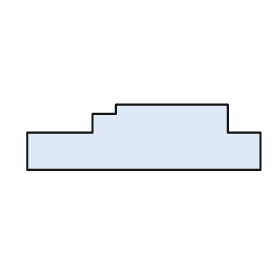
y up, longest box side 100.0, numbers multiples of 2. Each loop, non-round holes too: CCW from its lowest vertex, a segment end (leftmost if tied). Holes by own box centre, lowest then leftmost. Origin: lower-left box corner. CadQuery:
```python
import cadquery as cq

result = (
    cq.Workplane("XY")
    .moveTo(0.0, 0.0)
    .lineTo(100.0, 0.0)
    .lineTo(100.0, 16.0)
    .lineTo(86.0, 16.0)
    .lineTo(86.0, 28.0)
    .lineTo(38.0, 28.0)
    .lineTo(38.0, 24.0)
    .lineTo(28.0, 24.0)
    .lineTo(28.0, 16.0)
    .lineTo(0.0, 16.0)
    .close()
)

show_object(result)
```